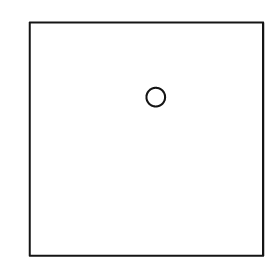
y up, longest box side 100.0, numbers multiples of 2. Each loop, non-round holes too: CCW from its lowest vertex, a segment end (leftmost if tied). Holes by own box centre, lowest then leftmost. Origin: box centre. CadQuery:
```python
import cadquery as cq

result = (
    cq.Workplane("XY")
    .moveTo(-50.0, -50.0)
    .lineTo(50.0, -50.0)
    .lineTo(50.0, 50.0)
    .lineTo(-50.0, 50.0)
    .close()
    .moveTo(4.0, 18.0)
    .circle(4.0)
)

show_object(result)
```